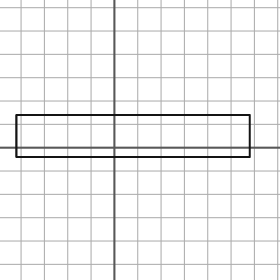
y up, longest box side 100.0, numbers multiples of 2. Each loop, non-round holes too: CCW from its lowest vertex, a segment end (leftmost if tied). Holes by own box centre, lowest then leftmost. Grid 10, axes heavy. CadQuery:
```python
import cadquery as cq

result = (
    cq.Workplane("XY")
    .moveTo(-42.0, -4.0)
    .lineTo(58.0, -4.0)
    .lineTo(58.0, 14.0)
    .lineTo(-42.0, 14.0)
    .close()
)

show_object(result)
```